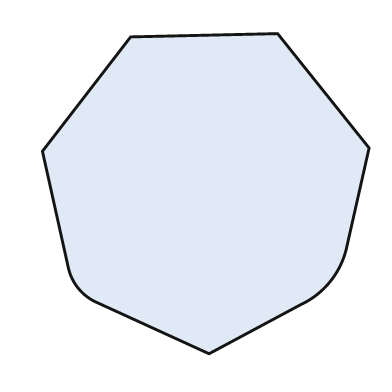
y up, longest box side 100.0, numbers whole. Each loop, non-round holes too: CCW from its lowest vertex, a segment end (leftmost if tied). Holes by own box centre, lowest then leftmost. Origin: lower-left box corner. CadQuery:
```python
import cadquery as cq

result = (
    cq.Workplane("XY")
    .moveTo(51.0, 0.0)
    .lineTo(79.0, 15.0)
    .threePointArc((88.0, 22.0), (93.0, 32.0))
    .lineTo(100.0, 63.0)
    .lineTo(72.0, 98.0)
    .lineTo(27.0, 97.0)
    .lineTo(0.0, 62.0)
    .lineTo(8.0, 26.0)
    .threePointArc((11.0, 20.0), (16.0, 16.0))
    .close()
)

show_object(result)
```